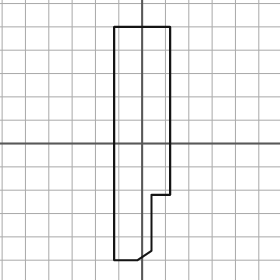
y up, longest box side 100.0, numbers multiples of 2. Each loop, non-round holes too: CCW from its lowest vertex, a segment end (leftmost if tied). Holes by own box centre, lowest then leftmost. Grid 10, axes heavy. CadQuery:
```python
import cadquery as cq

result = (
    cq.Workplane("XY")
    .moveTo(-12.0, -50.0)
    .lineTo(-2.0, -50.0)
    .lineTo(4.0, -46.0)
    .lineTo(4.0, -22.0)
    .lineTo(12.0, -22.0)
    .lineTo(12.0, 50.0)
    .lineTo(-12.0, 50.0)
    .close()
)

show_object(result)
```